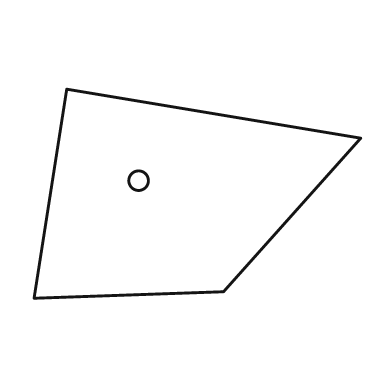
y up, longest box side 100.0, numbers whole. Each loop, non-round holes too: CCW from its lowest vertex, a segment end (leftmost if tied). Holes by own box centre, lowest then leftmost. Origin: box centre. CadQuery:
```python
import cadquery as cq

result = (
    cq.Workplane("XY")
    .moveTo(-50.0, -32.0)
    .lineTo(8.0, -30.0)
    .lineTo(50.0, 17.0)
    .lineTo(-40.0, 32.0)
    .close()
    .moveTo(-18.0, 4.0)
    .circle(3.0)
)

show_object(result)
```